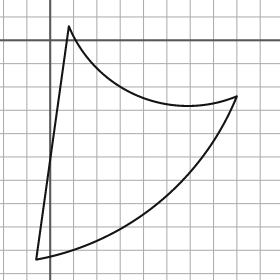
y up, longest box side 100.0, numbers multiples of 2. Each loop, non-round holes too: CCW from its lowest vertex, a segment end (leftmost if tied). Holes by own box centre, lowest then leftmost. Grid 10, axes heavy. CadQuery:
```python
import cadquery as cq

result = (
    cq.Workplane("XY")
    .moveTo(-6.0, -94.0)
    .threePointArc((46.0, -70.0), (80.0, -24.0))
    .threePointArc((38.0, -24.0), (8.0, 6.0))
    .close()
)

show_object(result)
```